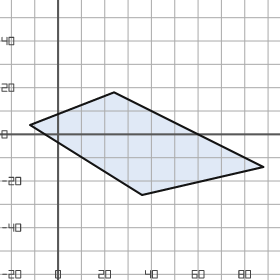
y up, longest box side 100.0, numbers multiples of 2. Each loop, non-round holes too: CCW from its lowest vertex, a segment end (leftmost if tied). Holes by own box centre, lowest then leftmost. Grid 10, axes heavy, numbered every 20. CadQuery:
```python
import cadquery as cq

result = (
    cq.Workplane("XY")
    .moveTo(36.0, -26.0)
    .lineTo(88.0, -14.0)
    .lineTo(24.0, 18.0)
    .lineTo(-12.0, 4.0)
    .close()
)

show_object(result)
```